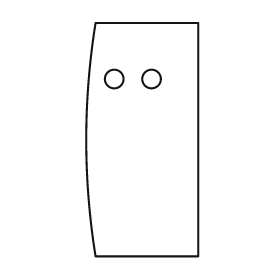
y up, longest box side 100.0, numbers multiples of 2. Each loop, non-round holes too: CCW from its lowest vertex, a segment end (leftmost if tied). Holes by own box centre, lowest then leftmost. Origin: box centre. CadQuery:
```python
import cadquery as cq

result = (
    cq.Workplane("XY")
    .moveTo(-20.0, -50.0)
    .lineTo(24.0, -50.0)
    .lineTo(24.0, 50.0)
    .lineTo(-20.0, 50.0)
    .threePointArc((-24.0, 0.0), (-20.0, -50.0))
    .close()
    .moveTo(-12.0, 26.0)
    .circle(4.0)
    .moveTo(4.0, 26.0)
    .circle(4.0)
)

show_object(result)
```